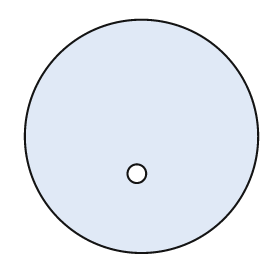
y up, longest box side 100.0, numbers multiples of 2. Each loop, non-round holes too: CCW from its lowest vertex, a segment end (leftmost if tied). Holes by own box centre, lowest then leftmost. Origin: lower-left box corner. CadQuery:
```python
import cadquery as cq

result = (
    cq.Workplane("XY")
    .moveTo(50.0, 50.0)
    .circle(50.0)
    .moveTo(48.0, 34.0)
    .circle(4.0)
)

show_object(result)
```